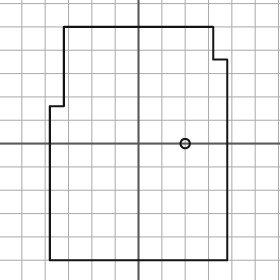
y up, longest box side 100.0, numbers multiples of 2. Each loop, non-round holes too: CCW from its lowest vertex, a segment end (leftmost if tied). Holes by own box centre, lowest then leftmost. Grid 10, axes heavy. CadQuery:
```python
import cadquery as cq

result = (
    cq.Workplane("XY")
    .moveTo(-38.0, -50.0)
    .lineTo(38.0, -50.0)
    .lineTo(38.0, 36.0)
    .lineTo(32.0, 36.0)
    .lineTo(32.0, 50.0)
    .lineTo(-32.0, 50.0)
    .lineTo(-32.0, 16.0)
    .lineTo(-38.0, 16.0)
    .close()
    .moveTo(20.0, 0.0)
    .circle(2.0)
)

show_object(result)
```